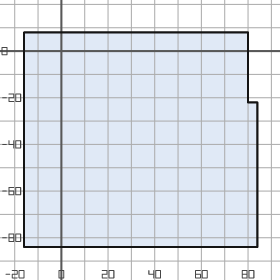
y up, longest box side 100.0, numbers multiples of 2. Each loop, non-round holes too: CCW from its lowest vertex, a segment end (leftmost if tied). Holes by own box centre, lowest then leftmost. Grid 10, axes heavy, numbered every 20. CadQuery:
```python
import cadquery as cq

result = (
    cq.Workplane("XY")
    .moveTo(-16.0, -84.0)
    .lineTo(84.0, -84.0)
    .lineTo(84.0, -22.0)
    .lineTo(80.0, -22.0)
    .lineTo(80.0, 8.0)
    .lineTo(-16.0, 8.0)
    .close()
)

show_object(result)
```